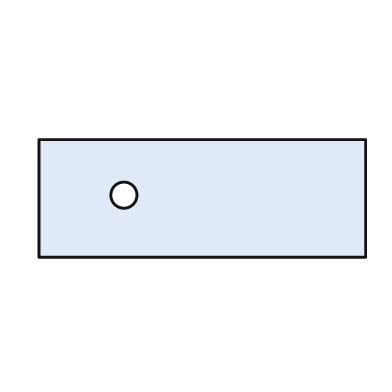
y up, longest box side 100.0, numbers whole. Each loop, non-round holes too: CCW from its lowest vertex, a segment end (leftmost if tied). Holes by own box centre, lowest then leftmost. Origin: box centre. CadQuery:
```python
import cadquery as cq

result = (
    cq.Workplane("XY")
    .moveTo(-50.0, -18.0)
    .lineTo(50.0, -18.0)
    .lineTo(50.0, 18.0)
    .lineTo(-50.0, 18.0)
    .close()
    .moveTo(-24.0, 1.0)
    .circle(4.0)
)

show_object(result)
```